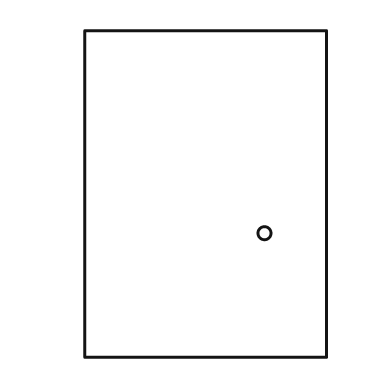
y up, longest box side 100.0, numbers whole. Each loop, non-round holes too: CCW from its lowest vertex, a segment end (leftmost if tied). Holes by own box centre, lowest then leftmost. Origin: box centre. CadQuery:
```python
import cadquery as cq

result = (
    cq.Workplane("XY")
    .moveTo(-37.0, -50.0)
    .lineTo(37.0, -50.0)
    .lineTo(37.0, 50.0)
    .lineTo(-37.0, 50.0)
    .close()
    .moveTo(18.0, -12.0)
    .circle(2.0)
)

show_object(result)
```